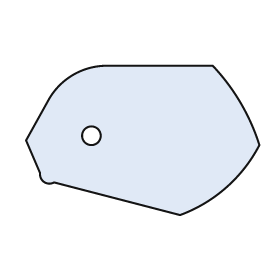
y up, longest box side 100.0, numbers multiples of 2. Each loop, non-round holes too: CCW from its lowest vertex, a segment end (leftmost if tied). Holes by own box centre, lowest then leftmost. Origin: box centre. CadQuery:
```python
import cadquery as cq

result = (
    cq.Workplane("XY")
    .moveTo(16.0, -32.0)
    .threePointArc((36.0, -20.0), (50.0, -2.0))
    .threePointArc((42.0, 16.0), (30.0, 32.0))
    .lineTo(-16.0, 32.0)
    .threePointArc((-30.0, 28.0), (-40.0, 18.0))
    .lineTo(-50.0, 0.0)
    .lineTo(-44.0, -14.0)
    .threePointArc((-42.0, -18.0), (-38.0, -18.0))
    .close()
    .moveTo(-22.0, 2.0)
    .circle(4.0)
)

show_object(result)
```